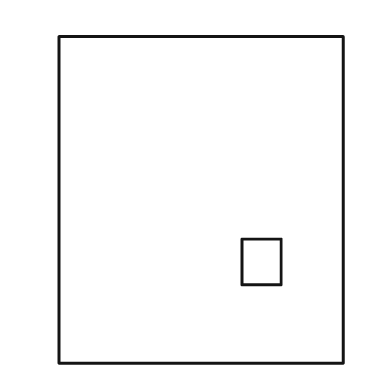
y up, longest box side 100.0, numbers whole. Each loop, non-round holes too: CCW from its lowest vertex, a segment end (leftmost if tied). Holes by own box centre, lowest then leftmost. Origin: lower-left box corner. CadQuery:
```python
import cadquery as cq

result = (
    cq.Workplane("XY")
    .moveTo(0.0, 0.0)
    .lineTo(87.0, 0.0)
    .lineTo(87.0, 100.0)
    .lineTo(0.0, 100.0)
    .close()
    .moveTo(56.0, 24.0)
    .lineTo(68.0, 24.0)
    .lineTo(68.0, 38.0)
    .lineTo(56.0, 38.0)
    .close()
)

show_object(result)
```